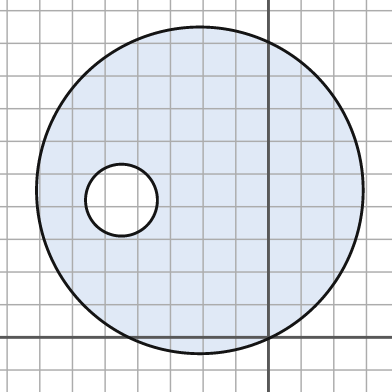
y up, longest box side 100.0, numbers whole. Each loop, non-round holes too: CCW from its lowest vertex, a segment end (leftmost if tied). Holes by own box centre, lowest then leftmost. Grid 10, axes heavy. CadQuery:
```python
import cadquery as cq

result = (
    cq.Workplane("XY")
    .moveTo(-21.0, 45.0)
    .circle(50.0)
    .moveTo(-45.0, 42.0)
    .circle(11.0)
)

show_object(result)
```